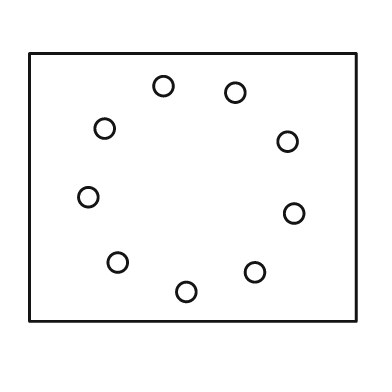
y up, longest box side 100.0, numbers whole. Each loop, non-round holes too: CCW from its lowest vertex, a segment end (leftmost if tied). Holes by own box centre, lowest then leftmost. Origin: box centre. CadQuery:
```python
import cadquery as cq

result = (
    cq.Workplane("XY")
    .moveTo(-50.0, -41.0)
    .lineTo(50.0, -41.0)
    .lineTo(50.0, 41.0)
    .lineTo(-50.0, 41.0)
    .close()
    .moveTo(-2.0, -32.0)
    .circle(3.0)
    .moveTo(19.0, -26.0)
    .circle(3.0)
    .moveTo(-23.0, -23.0)
    .circle(3.0)
    .moveTo(31.0, -8.0)
    .circle(3.0)
    .moveTo(-32.0, -3.0)
    .circle(3.0)
    .moveTo(29.0, 14.0)
    .circle(3.0)
    .moveTo(-27.0, 18.0)
    .circle(3.0)
    .moveTo(13.0, 29.0)
    .circle(3.0)
    .moveTo(-9.0, 31.0)
    .circle(3.0)
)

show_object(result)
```